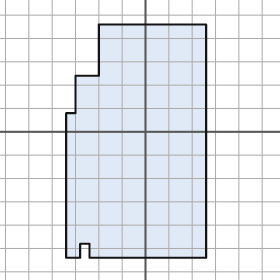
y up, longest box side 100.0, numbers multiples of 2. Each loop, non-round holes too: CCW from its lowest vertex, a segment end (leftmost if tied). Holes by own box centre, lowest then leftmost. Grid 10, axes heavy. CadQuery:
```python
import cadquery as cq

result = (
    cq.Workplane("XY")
    .moveTo(-34.0, -54.0)
    .lineTo(-28.0, -54.0)
    .lineTo(-28.0, -48.0)
    .lineTo(-24.0, -48.0)
    .lineTo(-24.0, -54.0)
    .lineTo(26.0, -54.0)
    .lineTo(26.0, 46.0)
    .lineTo(-20.0, 46.0)
    .lineTo(-20.0, 24.0)
    .lineTo(-30.0, 24.0)
    .lineTo(-30.0, 8.0)
    .lineTo(-34.0, 8.0)
    .close()
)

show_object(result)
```